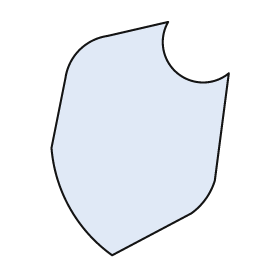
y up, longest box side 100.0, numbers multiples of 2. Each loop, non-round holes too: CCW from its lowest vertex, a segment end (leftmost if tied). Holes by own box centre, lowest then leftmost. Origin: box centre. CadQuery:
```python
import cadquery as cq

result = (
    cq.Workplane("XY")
    .moveTo(-12.0, -50.0)
    .lineTo(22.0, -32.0)
    .threePointArc((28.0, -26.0), (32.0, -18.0))
    .lineTo(38.0, 28.0)
    .threePointArc((16.0, 28.0), (12.0, 50.0))
    .lineTo(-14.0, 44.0)
    .threePointArc((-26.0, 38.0), (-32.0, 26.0))
    .lineTo(-38.0, -4.0)
    .threePointArc((-30.0, -30.0), (-12.0, -50.0))
    .close()
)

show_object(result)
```